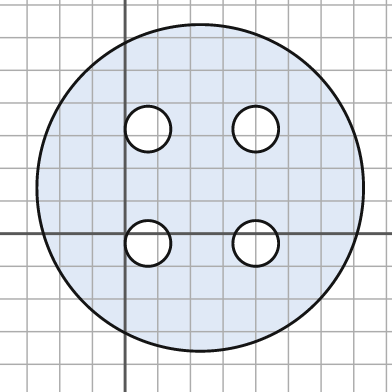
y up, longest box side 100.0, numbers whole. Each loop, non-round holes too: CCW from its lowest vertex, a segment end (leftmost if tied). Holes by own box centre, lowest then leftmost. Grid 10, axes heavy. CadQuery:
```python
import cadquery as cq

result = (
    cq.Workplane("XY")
    .moveTo(23.0, 14.0)
    .circle(50.0)
    .moveTo(7.0, -3.0)
    .circle(7.0)
    .moveTo(40.0, -3.0)
    .circle(7.0)
    .moveTo(7.0, 32.0)
    .circle(7.0)
    .moveTo(40.0, 32.0)
    .circle(7.0)
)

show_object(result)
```